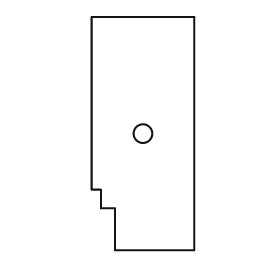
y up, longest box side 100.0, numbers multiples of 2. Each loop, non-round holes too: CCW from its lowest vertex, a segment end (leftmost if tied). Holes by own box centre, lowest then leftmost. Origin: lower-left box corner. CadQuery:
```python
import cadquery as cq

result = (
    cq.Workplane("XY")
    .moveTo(10.0, 0.0)
    .lineTo(44.0, 0.0)
    .lineTo(44.0, 100.0)
    .lineTo(0.0, 100.0)
    .lineTo(0.0, 26.0)
    .lineTo(4.0, 26.0)
    .lineTo(4.0, 18.0)
    .lineTo(10.0, 18.0)
    .close()
    .moveTo(22.0, 50.0)
    .circle(4.0)
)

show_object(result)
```